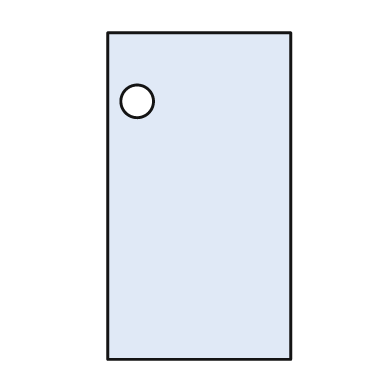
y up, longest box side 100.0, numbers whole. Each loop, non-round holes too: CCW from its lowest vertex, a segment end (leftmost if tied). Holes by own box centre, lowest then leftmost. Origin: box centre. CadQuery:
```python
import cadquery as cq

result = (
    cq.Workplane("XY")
    .moveTo(-28.0, -50.0)
    .lineTo(28.0, -50.0)
    .lineTo(28.0, 50.0)
    .lineTo(-28.0, 50.0)
    .close()
    .moveTo(-19.0, 29.0)
    .circle(5.0)
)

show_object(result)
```